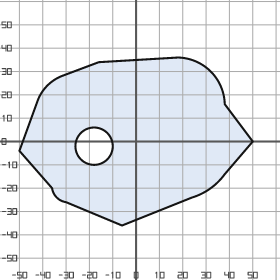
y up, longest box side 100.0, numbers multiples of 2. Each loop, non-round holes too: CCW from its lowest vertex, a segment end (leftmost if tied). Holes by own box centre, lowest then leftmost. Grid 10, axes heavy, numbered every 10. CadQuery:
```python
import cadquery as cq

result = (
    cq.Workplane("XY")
    .moveTo(-6.0, -36.0)
    .lineTo(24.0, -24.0)
    .threePointArc((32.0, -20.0), (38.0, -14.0))
    .lineTo(50.0, 0.0)
    .lineTo(38.0, 16.0)
    .threePointArc((32.0, 30.0), (18.0, 36.0))
    .lineTo(-16.0, 34.0)
    .lineTo(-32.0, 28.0)
    .threePointArc((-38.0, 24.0), (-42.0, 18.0))
    .lineTo(-50.0, -4.0)
    .lineTo(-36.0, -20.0)
    .threePointArc((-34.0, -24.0), (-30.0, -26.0))
    .close()
    .moveTo(-18.0, -2.0)
    .circle(8.0)
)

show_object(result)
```